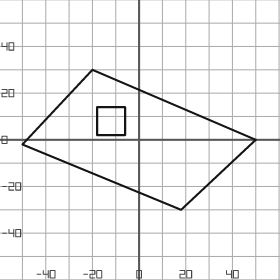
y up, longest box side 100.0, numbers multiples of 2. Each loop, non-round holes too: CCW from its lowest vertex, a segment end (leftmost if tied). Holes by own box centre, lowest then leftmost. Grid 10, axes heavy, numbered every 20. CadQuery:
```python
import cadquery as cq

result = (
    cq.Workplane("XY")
    .moveTo(18.0, -30.0)
    .lineTo(50.0, 0.0)
    .lineTo(-20.0, 30.0)
    .lineTo(-50.0, -2.0)
    .close()
    .moveTo(-18.0, 2.0)
    .lineTo(-6.0, 2.0)
    .lineTo(-6.0, 14.0)
    .lineTo(-18.0, 14.0)
    .close()
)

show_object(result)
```